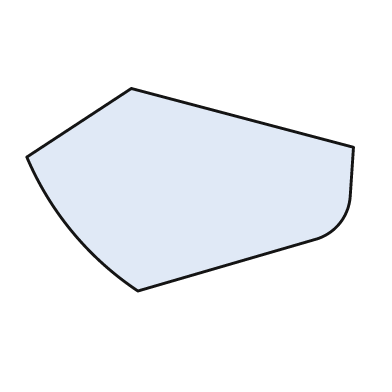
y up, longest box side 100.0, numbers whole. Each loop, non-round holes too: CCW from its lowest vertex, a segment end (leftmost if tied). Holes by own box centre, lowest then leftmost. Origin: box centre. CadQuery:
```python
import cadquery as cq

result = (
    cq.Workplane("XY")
    .moveTo(-16.0, -31.0)
    .lineTo(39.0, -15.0)
    .threePointArc((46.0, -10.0), (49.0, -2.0))
    .lineTo(50.0, 13.0)
    .lineTo(-18.0, 31.0)
    .lineTo(-50.0, 10.0)
    .threePointArc((-36.0, -13.0), (-16.0, -31.0))
    .close()
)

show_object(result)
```